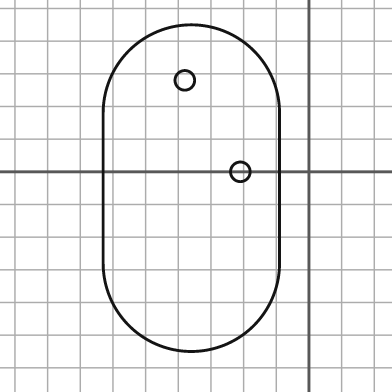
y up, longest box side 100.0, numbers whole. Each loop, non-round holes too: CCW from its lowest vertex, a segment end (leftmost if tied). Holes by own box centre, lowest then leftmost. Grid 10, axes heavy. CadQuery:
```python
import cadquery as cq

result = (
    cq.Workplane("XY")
    .moveTo(-63.0, -28.0)
    .threePointArc((-36.0, -55.0), (-9.0, -28.0))
    .lineTo(-9.0, 18.0)
    .threePointArc((-36.0, 45.0), (-63.0, 18.0))
    .close()
    .moveTo(-21.0, 0.0)
    .circle(3.0)
    .moveTo(-38.0, 28.0)
    .circle(3.0)
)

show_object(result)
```